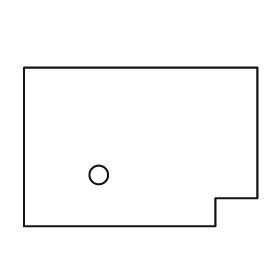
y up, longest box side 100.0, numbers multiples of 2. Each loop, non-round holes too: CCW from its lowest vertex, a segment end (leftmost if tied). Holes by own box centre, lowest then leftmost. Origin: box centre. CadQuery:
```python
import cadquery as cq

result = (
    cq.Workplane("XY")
    .moveTo(-50.0, -34.0)
    .lineTo(32.0, -34.0)
    .lineTo(32.0, -22.0)
    .lineTo(50.0, -22.0)
    .lineTo(50.0, 34.0)
    .lineTo(-50.0, 34.0)
    .close()
    .moveTo(-18.0, -12.0)
    .circle(4.0)
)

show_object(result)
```